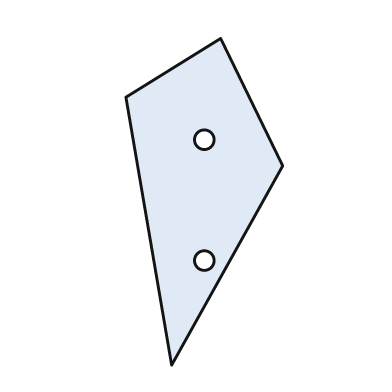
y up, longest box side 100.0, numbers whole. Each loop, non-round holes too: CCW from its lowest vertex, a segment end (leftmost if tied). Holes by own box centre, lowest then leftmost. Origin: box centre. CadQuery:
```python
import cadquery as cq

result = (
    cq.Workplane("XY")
    .moveTo(-10.0, -50.0)
    .lineTo(24.0, 11.0)
    .lineTo(5.0, 50.0)
    .lineTo(-24.0, 32.0)
    .close()
    .moveTo(0.0, -18.0)
    .circle(3.0)
    .moveTo(0.0, 19.0)
    .circle(3.0)
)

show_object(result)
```